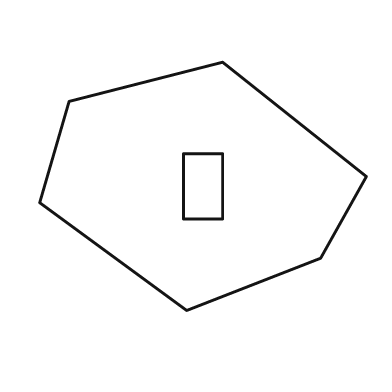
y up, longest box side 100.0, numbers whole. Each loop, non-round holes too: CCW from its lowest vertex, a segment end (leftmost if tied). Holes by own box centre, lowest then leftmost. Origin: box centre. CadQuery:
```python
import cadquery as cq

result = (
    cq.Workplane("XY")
    .moveTo(-5.0, -38.0)
    .lineTo(36.0, -22.0)
    .lineTo(50.0, 3.0)
    .lineTo(6.0, 38.0)
    .lineTo(-41.0, 26.0)
    .lineTo(-50.0, -5.0)
    .close()
    .moveTo(-6.0, -10.0)
    .lineTo(6.0, -10.0)
    .lineTo(6.0, 10.0)
    .lineTo(-6.0, 10.0)
    .close()
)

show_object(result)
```